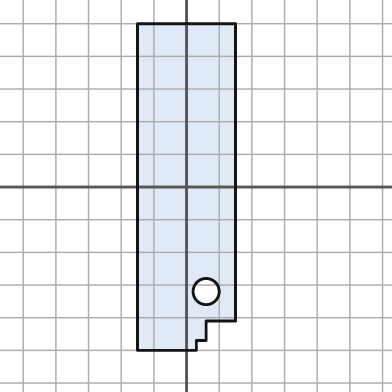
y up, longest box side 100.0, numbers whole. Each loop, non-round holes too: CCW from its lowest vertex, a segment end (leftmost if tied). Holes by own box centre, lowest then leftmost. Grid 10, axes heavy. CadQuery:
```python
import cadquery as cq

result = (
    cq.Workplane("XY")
    .moveTo(-15.0, -50.0)
    .lineTo(3.0, -50.0)
    .lineTo(3.0, -47.0)
    .lineTo(6.0, -47.0)
    .lineTo(6.0, -41.0)
    .lineTo(15.0, -41.0)
    .lineTo(15.0, 50.0)
    .lineTo(-15.0, 50.0)
    .close()
    .moveTo(6.0, -32.0)
    .circle(4.0)
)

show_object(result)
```